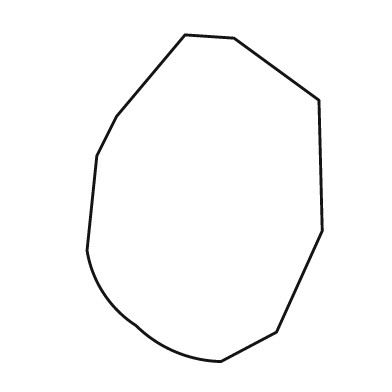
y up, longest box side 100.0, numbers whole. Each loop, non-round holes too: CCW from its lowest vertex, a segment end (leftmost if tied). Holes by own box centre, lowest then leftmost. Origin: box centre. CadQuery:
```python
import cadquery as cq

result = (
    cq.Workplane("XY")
    .moveTo(5.0, -50.0)
    .lineTo(22.0, -41.0)
    .lineTo(36.0, -10.0)
    .lineTo(35.0, 30.0)
    .lineTo(9.0, 49.0)
    .lineTo(-6.0, 50.0)
    .lineTo(-27.0, 25.0)
    .lineTo(-33.0, 13.0)
    .lineTo(-36.0, -16.0)
    .threePointArc((-31.0, -29.0), (-21.0, -39.0))
    .threePointArc((-9.0, -47.0), (5.0, -50.0))
    .close()
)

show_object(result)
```